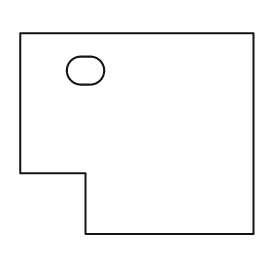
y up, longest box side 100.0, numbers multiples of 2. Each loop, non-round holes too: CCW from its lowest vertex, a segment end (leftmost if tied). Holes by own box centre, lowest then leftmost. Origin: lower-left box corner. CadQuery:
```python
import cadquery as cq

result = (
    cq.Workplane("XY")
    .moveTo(28.0, 0.0)
    .lineTo(100.0, 0.0)
    .lineTo(100.0, 86.0)
    .lineTo(0.0, 86.0)
    .lineTo(0.0, 26.0)
    .lineTo(28.0, 26.0)
    .close()
    .moveTo(26.0, 64.0)
    .lineTo(30.0, 64.0)
    .threePointArc((36.0, 70.0), (30.0, 76.0))
    .lineTo(26.0, 76.0)
    .threePointArc((20.0, 70.0), (26.0, 64.0))
    .close()
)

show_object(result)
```